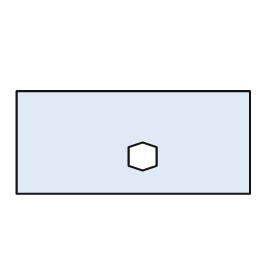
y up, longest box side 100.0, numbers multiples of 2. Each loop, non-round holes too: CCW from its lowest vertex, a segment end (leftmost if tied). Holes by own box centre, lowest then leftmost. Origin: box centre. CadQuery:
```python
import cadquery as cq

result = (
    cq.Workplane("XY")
    .moveTo(-50.0, -22.0)
    .lineTo(50.0, -22.0)
    .lineTo(50.0, 22.0)
    .lineTo(-50.0, 22.0)
    .close()
    .moveTo(4.0, -12.0)
    .lineTo(10.0, -10.0)
    .lineTo(10.0, -2.0)
    .lineTo(4.0, 0.0)
    .lineTo(-2.0, -2.0)
    .lineTo(-2.0, -10.0)
    .close()
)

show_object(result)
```